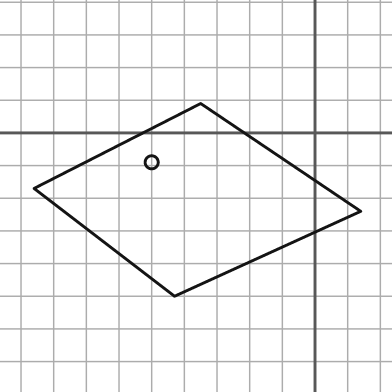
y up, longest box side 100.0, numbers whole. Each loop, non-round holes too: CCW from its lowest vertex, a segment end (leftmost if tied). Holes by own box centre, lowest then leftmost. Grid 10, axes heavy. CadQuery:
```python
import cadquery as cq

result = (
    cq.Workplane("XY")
    .moveTo(-43.0, -50.0)
    .lineTo(14.0, -24.0)
    .lineTo(-35.0, 9.0)
    .lineTo(-86.0, -17.0)
    .close()
    .moveTo(-50.0, -9.0)
    .circle(2.0)
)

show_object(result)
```